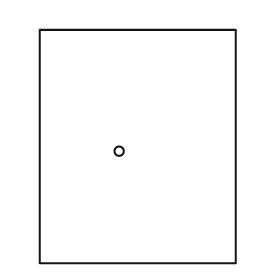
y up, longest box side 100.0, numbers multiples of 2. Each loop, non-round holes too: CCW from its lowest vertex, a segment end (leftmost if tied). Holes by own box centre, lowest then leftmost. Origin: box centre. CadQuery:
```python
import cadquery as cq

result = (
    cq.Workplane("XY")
    .moveTo(-42.0, -50.0)
    .lineTo(42.0, -50.0)
    .lineTo(42.0, 50.0)
    .lineTo(-42.0, 50.0)
    .close()
    .moveTo(-8.0, -2.0)
    .circle(2.0)
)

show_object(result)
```